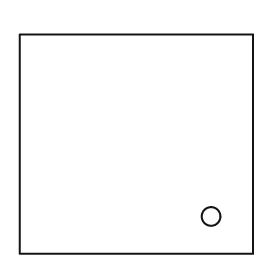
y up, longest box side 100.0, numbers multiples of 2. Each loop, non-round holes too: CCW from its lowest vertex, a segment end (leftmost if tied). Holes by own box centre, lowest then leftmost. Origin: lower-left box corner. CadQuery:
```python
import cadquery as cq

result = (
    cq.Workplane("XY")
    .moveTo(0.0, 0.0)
    .lineTo(100.0, 0.0)
    .lineTo(100.0, 94.0)
    .lineTo(0.0, 94.0)
    .close()
    .moveTo(82.0, 16.0)
    .circle(4.0)
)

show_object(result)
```